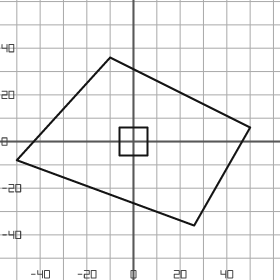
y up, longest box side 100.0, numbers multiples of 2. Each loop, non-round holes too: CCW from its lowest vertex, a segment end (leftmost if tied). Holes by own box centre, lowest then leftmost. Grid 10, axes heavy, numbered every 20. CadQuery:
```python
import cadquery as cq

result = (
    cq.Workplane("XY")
    .moveTo(26.0, -36.0)
    .lineTo(50.0, 6.0)
    .lineTo(-10.0, 36.0)
    .lineTo(-50.0, -8.0)
    .close()
    .moveTo(-6.0, -6.0)
    .lineTo(6.0, -6.0)
    .lineTo(6.0, 6.0)
    .lineTo(-6.0, 6.0)
    .close()
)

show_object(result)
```